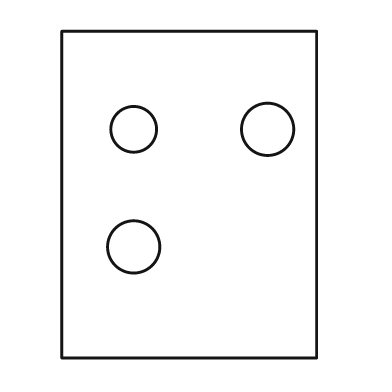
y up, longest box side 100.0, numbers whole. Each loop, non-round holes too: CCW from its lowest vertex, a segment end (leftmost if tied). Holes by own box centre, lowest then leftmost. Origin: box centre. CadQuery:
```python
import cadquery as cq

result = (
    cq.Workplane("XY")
    .moveTo(-39.0, -50.0)
    .lineTo(39.0, -50.0)
    .lineTo(39.0, 50.0)
    .lineTo(-39.0, 50.0)
    .close()
    .moveTo(-17.0, -16.0)
    .circle(8.0)
    .moveTo(-17.0, 20.0)
    .circle(7.0)
    .moveTo(24.0, 20.0)
    .circle(8.0)
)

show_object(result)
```